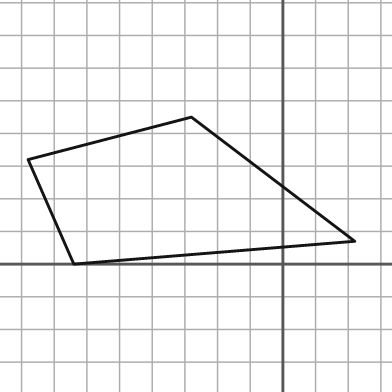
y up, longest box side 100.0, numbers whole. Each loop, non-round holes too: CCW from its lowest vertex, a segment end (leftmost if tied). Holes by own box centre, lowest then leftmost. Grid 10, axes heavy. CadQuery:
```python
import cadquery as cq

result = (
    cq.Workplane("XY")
    .moveTo(-64.0, 0.0)
    .lineTo(22.0, 7.0)
    .lineTo(-28.0, 45.0)
    .lineTo(-78.0, 32.0)
    .close()
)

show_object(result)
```